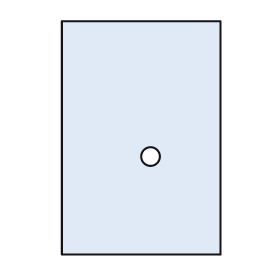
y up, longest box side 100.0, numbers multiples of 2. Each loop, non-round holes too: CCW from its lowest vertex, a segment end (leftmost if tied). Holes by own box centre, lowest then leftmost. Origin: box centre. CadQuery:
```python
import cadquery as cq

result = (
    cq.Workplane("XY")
    .moveTo(-34.0, -50.0)
    .lineTo(34.0, -50.0)
    .lineTo(34.0, 50.0)
    .lineTo(-34.0, 50.0)
    .close()
    .moveTo(4.0, -8.0)
    .circle(4.0)
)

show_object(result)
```